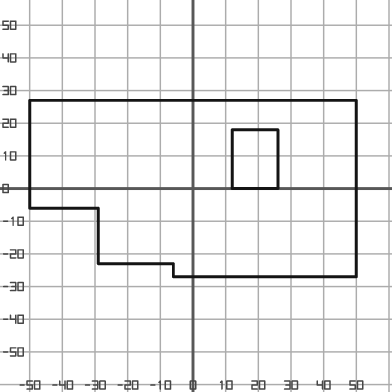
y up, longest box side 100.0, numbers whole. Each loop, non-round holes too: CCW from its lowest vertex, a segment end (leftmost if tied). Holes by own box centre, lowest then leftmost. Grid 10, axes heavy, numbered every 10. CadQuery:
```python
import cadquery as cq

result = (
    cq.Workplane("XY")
    .moveTo(-6.0, -27.0)
    .lineTo(50.0, -27.0)
    .lineTo(50.0, 27.0)
    .lineTo(-50.0, 27.0)
    .lineTo(-50.0, -6.0)
    .lineTo(-29.0, -6.0)
    .lineTo(-29.0, -23.0)
    .lineTo(-6.0, -23.0)
    .close()
    .moveTo(12.0, 0.0)
    .lineTo(26.0, 0.0)
    .lineTo(26.0, 18.0)
    .lineTo(12.0, 18.0)
    .close()
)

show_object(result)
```